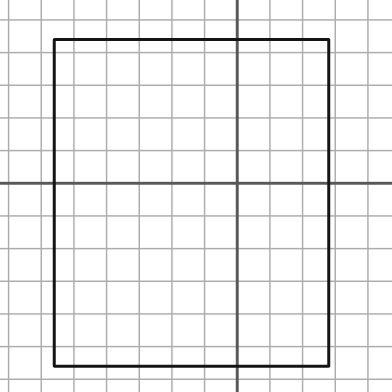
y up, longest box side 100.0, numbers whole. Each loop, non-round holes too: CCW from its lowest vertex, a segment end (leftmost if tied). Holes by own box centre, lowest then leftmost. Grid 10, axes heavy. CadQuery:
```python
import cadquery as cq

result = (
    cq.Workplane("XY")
    .moveTo(-56.0, -56.0)
    .lineTo(28.0, -56.0)
    .lineTo(28.0, 44.0)
    .lineTo(-56.0, 44.0)
    .close()
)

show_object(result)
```